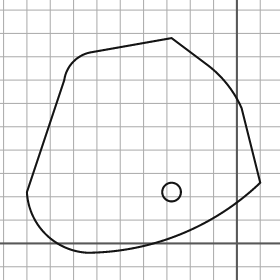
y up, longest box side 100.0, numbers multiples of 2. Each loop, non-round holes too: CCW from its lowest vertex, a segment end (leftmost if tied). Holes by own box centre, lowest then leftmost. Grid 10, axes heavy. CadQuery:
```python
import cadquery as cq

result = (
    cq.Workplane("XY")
    .moveTo(-64.0, -4.0)
    .threePointArc((-24.0, 4.0), (10.0, 26.0))
    .lineTo(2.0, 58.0)
    .threePointArc((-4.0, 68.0), (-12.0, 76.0))
    .lineTo(-28.0, 88.0)
    .lineTo(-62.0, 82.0)
    .threePointArc((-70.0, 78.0), (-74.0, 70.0))
    .lineTo(-90.0, 22.0)
    .threePointArc((-82.0, 4.0), (-64.0, -4.0))
    .close()
    .moveTo(-28.0, 22.0)
    .circle(4.0)
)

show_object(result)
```